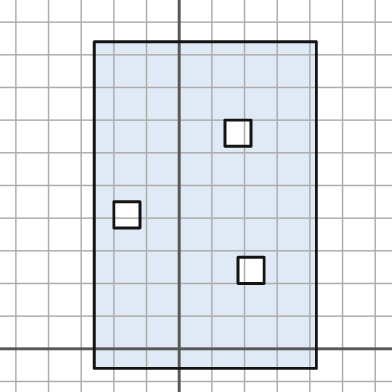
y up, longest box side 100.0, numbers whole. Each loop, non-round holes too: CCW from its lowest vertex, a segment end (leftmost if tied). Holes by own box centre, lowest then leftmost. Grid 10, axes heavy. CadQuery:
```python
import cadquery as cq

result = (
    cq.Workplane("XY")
    .moveTo(-26.0, -6.0)
    .lineTo(42.0, -6.0)
    .lineTo(42.0, 94.0)
    .lineTo(-26.0, 94.0)
    .close()
    .moveTo(18.0, 20.0)
    .lineTo(26.0, 20.0)
    .lineTo(26.0, 28.0)
    .lineTo(18.0, 28.0)
    .close()
    .moveTo(-20.0, 37.0)
    .lineTo(-12.0, 37.0)
    .lineTo(-12.0, 45.0)
    .lineTo(-20.0, 45.0)
    .close()
    .moveTo(14.0, 62.0)
    .lineTo(22.0, 62.0)
    .lineTo(22.0, 70.0)
    .lineTo(14.0, 70.0)
    .close()
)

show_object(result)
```